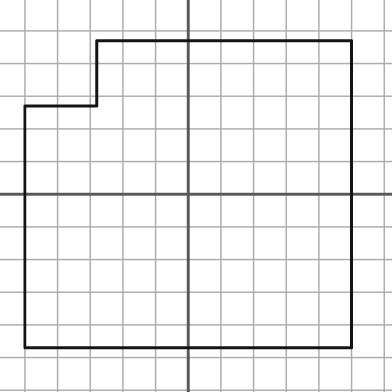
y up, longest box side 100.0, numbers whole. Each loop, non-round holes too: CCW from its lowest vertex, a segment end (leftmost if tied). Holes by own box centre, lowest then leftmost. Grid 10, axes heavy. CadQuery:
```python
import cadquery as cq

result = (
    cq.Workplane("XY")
    .moveTo(-50.0, -47.0)
    .lineTo(50.0, -47.0)
    .lineTo(50.0, 47.0)
    .lineTo(-28.0, 47.0)
    .lineTo(-28.0, 27.0)
    .lineTo(-50.0, 27.0)
    .close()
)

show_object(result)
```